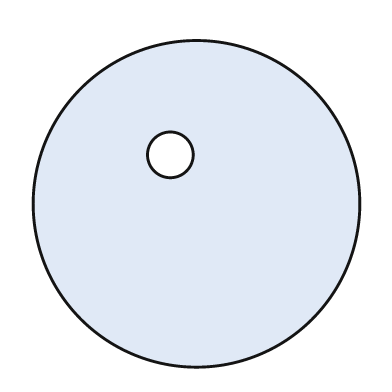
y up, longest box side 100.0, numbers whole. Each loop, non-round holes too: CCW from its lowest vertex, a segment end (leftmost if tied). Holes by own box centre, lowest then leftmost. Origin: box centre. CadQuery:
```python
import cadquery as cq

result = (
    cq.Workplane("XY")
    .moveTo(0.0, 0.0)
    .circle(50.0)
    .moveTo(-8.0, 15.0)
    .circle(7.0)
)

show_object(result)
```